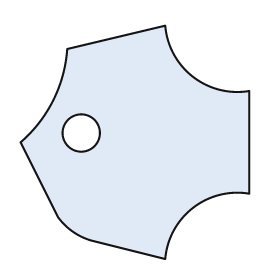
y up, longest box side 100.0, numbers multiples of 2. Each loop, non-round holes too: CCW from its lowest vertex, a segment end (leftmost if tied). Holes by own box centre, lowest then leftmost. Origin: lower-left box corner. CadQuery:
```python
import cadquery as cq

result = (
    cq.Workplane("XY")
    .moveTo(62.0, 0.0)
    .threePointArc((74.0, 22.0), (98.0, 28.0))
    .lineTo(98.0, 72.0)
    .threePointArc((74.0, 78.0), (62.0, 100.0))
    .lineTo(20.0, 90.0)
    .threePointArc((14.0, 68.0), (0.0, 50.0))
    .lineTo(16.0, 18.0)
    .threePointArc((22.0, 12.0), (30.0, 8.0))
    .close()
    .moveTo(26.0, 54.0)
    .circle(8.0)
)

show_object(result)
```